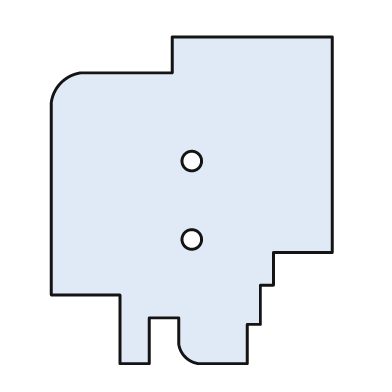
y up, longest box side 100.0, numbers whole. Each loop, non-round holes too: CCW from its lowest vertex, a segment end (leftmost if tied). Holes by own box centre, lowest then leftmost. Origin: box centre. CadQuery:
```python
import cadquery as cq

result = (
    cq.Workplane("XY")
    .moveTo(-22.0, -50.0)
    .lineTo(-13.0, -50.0)
    .lineTo(-13.0, -36.0)
    .lineTo(-4.0, -36.0)
    .lineTo(-4.0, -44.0)
    .threePointArc((-2.0, -48.0), (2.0, -50.0))
    .lineTo(17.0, -50.0)
    .lineTo(17.0, -38.0)
    .lineTo(21.0, -38.0)
    .lineTo(21.0, -26.0)
    .lineTo(25.0, -26.0)
    .lineTo(25.0, -16.0)
    .lineTo(43.0, -16.0)
    .lineTo(43.0, 50.0)
    .lineTo(-6.0, 50.0)
    .lineTo(-6.0, 39.0)
    .lineTo(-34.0, 39.0)
    .threePointArc((-40.0, 36.0), (-43.0, 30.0))
    .lineTo(-43.0, -29.0)
    .lineTo(-22.0, -29.0)
    .close()
    .moveTo(0.0, -12.0)
    .circle(3.0)
    .moveTo(0.0, 12.0)
    .circle(3.0)
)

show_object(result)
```